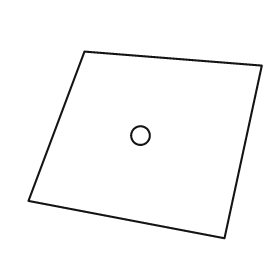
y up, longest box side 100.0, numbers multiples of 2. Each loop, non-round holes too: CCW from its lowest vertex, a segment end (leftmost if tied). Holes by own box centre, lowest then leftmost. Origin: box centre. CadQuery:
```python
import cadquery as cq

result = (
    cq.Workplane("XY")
    .moveTo(34.0, -40.0)
    .lineTo(50.0, 34.0)
    .lineTo(-26.0, 40.0)
    .lineTo(-50.0, -24.0)
    .close()
    .moveTo(-2.0, 4.0)
    .circle(4.0)
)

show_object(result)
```